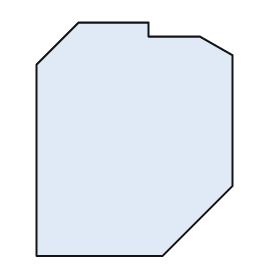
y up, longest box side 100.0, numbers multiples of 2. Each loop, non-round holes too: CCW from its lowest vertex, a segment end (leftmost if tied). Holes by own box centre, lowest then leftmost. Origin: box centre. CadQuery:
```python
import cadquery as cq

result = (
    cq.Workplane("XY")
    .moveTo(-42.0, -50.0)
    .lineTo(12.0, -50.0)
    .lineTo(42.0, -20.0)
    .lineTo(42.0, 36.0)
    .lineTo(28.0, 44.0)
    .lineTo(6.0, 44.0)
    .lineTo(6.0, 50.0)
    .lineTo(-24.0, 50.0)
    .lineTo(-42.0, 32.0)
    .close()
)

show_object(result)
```